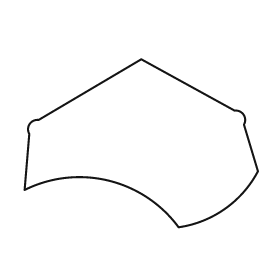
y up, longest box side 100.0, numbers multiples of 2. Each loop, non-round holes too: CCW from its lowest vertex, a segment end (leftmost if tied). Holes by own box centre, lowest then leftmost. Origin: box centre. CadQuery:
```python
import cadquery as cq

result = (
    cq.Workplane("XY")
    .moveTo(16.0, -36.0)
    .threePointArc((36.0, -28.0), (50.0, -12.0))
    .lineTo(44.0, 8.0)
    .threePointArc((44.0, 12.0), (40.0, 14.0))
    .lineTo(0.0, 36.0)
    .lineTo(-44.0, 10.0)
    .threePointArc((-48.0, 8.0), (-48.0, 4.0))
    .lineTo(-50.0, -20.0)
    .threePointArc((-14.0, -16.0), (16.0, -36.0))
    .close()
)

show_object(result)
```